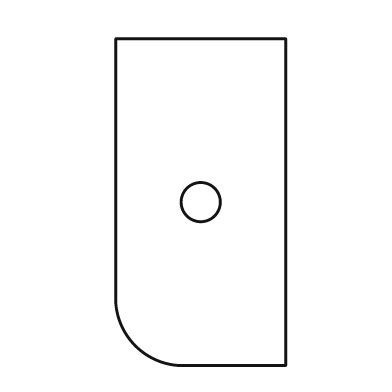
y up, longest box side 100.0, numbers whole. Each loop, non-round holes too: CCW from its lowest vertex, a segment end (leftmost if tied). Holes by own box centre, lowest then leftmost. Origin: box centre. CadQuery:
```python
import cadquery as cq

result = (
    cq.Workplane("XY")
    .moveTo(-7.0, -50.0)
    .lineTo(26.0, -50.0)
    .lineTo(26.0, 50.0)
    .lineTo(-26.0, 50.0)
    .lineTo(-26.0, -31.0)
    .threePointArc((-20.0, -44.0), (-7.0, -50.0))
    .close()
    .moveTo(0.0, 0.0)
    .circle(6.0)
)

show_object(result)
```